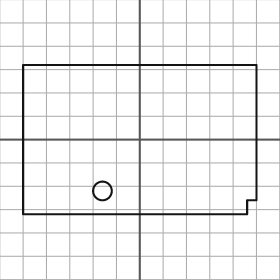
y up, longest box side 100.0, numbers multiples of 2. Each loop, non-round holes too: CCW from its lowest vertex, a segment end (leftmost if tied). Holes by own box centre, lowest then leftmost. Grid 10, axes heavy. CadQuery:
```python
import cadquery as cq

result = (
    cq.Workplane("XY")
    .moveTo(-50.0, -32.0)
    .lineTo(46.0, -32.0)
    .lineTo(46.0, -26.0)
    .lineTo(50.0, -26.0)
    .lineTo(50.0, 32.0)
    .lineTo(-50.0, 32.0)
    .close()
    .moveTo(-16.0, -22.0)
    .circle(4.0)
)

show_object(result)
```